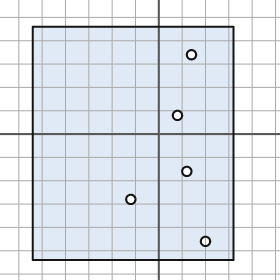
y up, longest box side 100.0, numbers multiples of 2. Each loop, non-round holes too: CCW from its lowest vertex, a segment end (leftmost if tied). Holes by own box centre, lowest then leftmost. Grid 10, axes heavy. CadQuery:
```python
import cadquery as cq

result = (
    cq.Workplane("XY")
    .moveTo(-54.0, -54.0)
    .lineTo(32.0, -54.0)
    .lineTo(32.0, 46.0)
    .lineTo(-54.0, 46.0)
    .close()
    .moveTo(20.0, -46.0)
    .circle(2.0)
    .moveTo(-12.0, -28.0)
    .circle(2.0)
    .moveTo(12.0, -16.0)
    .circle(2.0)
    .moveTo(8.0, 8.0)
    .circle(2.0)
    .moveTo(14.0, 34.0)
    .circle(2.0)
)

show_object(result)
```